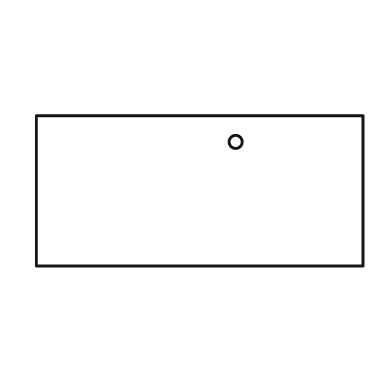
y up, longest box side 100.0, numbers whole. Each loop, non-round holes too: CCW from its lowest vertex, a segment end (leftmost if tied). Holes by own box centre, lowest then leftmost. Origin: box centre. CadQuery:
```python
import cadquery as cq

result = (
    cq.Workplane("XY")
    .moveTo(-50.0, -23.0)
    .lineTo(50.0, -23.0)
    .lineTo(50.0, 23.0)
    .lineTo(-50.0, 23.0)
    .close()
    .moveTo(11.0, 15.0)
    .circle(2.0)
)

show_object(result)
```